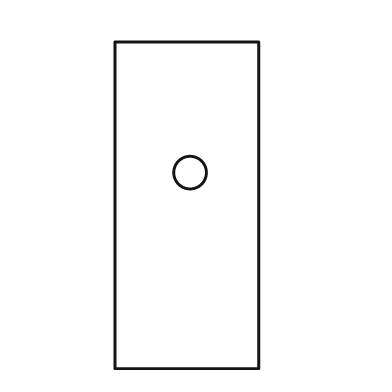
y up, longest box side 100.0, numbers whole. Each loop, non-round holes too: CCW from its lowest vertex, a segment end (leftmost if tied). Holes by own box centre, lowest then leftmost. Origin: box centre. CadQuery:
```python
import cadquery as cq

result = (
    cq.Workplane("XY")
    .moveTo(-22.0, -50.0)
    .lineTo(22.0, -50.0)
    .lineTo(22.0, 50.0)
    .lineTo(-22.0, 50.0)
    .close()
    .moveTo(1.0, 10.0)
    .circle(5.0)
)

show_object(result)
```